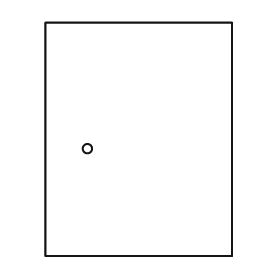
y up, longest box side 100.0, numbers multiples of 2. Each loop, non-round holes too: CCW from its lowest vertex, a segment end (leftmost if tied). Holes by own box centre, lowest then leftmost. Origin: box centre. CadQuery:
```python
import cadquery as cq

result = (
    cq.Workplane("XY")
    .moveTo(-40.0, -50.0)
    .lineTo(40.0, -50.0)
    .lineTo(40.0, 50.0)
    .lineTo(-40.0, 50.0)
    .close()
    .moveTo(-22.0, -4.0)
    .circle(2.0)
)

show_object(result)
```